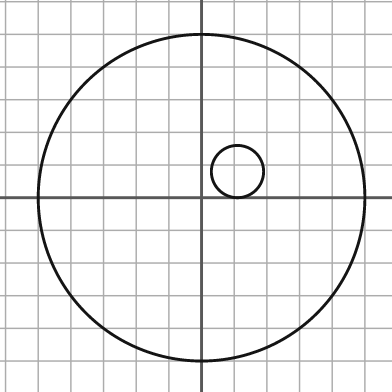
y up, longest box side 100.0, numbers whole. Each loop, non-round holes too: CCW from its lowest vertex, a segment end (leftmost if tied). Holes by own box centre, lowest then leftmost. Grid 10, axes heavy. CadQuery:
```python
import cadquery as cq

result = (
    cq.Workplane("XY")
    .moveTo(0.0, 0.0)
    .circle(50.0)
    .moveTo(11.0, 8.0)
    .circle(8.0)
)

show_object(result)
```